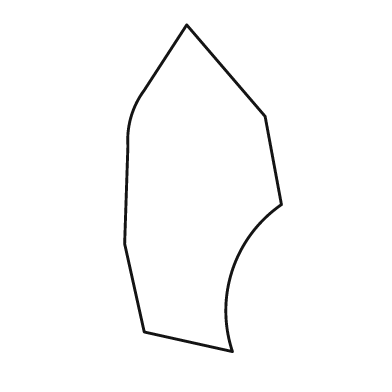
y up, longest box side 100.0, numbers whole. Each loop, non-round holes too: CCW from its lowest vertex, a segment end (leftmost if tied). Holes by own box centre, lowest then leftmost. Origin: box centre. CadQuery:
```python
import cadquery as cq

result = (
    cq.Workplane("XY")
    .moveTo(9.0, -50.0)
    .threePointArc((9.0, -25.0), (24.0, -5.0))
    .lineTo(19.0, 22.0)
    .lineTo(-5.0, 50.0)
    .lineTo(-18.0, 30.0)
    .threePointArc((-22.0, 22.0), (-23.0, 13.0))
    .lineTo(-24.0, -17.0)
    .lineTo(-18.0, -44.0)
    .close()
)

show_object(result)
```